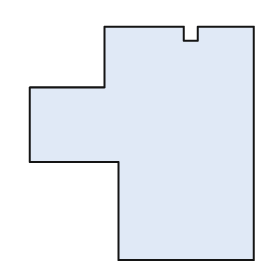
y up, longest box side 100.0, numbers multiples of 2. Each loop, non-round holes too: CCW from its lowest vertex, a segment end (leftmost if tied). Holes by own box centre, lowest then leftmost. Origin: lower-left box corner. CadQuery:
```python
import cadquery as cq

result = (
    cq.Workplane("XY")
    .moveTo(38.0, 0.0)
    .lineTo(96.0, 0.0)
    .lineTo(96.0, 100.0)
    .lineTo(72.0, 100.0)
    .lineTo(72.0, 94.0)
    .lineTo(66.0, 94.0)
    .lineTo(66.0, 100.0)
    .lineTo(32.0, 100.0)
    .lineTo(32.0, 74.0)
    .lineTo(0.0, 74.0)
    .lineTo(0.0, 42.0)
    .lineTo(38.0, 42.0)
    .close()
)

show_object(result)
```